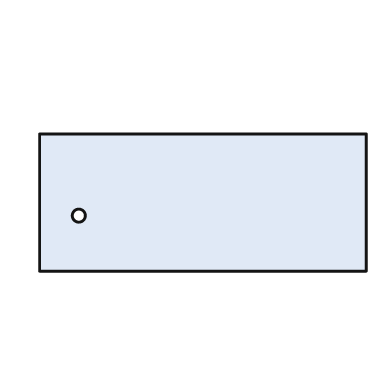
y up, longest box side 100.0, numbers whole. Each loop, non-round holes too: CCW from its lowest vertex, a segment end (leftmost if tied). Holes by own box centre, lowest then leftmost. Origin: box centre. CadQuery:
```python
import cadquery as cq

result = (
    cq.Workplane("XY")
    .moveTo(-50.0, -21.0)
    .lineTo(50.0, -21.0)
    .lineTo(50.0, 21.0)
    .lineTo(-50.0, 21.0)
    .close()
    .moveTo(-38.0, -4.0)
    .circle(2.0)
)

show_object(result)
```